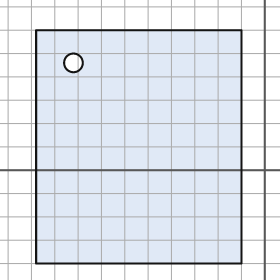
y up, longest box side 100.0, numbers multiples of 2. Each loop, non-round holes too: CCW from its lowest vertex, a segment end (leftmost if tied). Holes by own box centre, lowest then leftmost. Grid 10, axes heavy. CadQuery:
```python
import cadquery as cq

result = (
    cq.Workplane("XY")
    .moveTo(-98.0, -40.0)
    .lineTo(-10.0, -40.0)
    .lineTo(-10.0, 60.0)
    .lineTo(-98.0, 60.0)
    .close()
    .moveTo(-82.0, 46.0)
    .circle(4.0)
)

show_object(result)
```